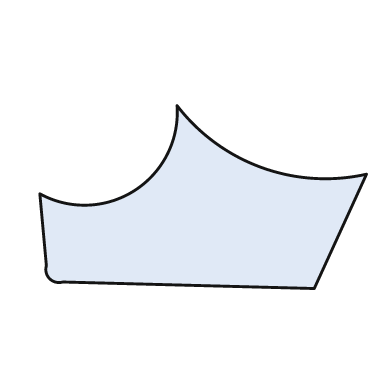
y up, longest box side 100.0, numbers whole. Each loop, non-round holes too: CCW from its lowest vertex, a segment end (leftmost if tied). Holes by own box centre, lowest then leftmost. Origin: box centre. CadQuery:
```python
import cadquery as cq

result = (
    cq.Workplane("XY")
    .moveTo(34.0, -28.0)
    .lineTo(50.0, 7.0)
    .threePointArc((18.0, 9.0), (-8.0, 28.0))
    .threePointArc((-21.0, 2.0), (-50.0, 1.0))
    .lineTo(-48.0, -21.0)
    .threePointArc((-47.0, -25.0), (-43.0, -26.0))
    .close()
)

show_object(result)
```